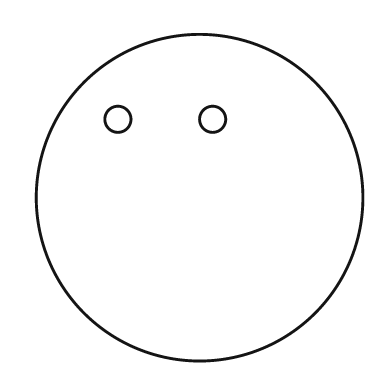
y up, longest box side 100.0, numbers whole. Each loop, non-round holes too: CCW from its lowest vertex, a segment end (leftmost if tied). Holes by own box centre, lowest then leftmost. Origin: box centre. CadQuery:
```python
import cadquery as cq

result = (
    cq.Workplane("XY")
    .moveTo(0.0, 0.0)
    .circle(50.0)
    .moveTo(-25.0, 24.0)
    .circle(4.0)
    .moveTo(4.0, 24.0)
    .circle(4.0)
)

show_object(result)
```